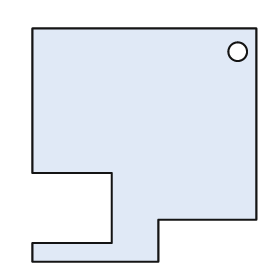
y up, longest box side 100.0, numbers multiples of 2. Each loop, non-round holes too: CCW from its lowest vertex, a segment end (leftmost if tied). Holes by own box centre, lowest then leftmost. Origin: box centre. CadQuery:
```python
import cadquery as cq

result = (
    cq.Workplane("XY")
    .moveTo(-48.0, -50.0)
    .lineTo(6.0, -50.0)
    .lineTo(6.0, -32.0)
    .lineTo(48.0, -32.0)
    .lineTo(48.0, 50.0)
    .lineTo(-48.0, 50.0)
    .lineTo(-48.0, -12.0)
    .lineTo(-14.0, -12.0)
    .lineTo(-14.0, -42.0)
    .lineTo(-48.0, -42.0)
    .close()
    .moveTo(40.0, 40.0)
    .circle(4.0)
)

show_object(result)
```